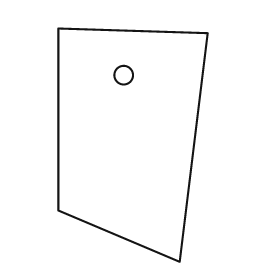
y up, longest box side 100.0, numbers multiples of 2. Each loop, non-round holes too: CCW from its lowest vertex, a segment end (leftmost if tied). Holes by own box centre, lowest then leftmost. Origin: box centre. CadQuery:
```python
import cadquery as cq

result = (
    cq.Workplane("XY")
    .moveTo(20.0, -50.0)
    .lineTo(32.0, 48.0)
    .lineTo(-32.0, 50.0)
    .lineTo(-32.0, -28.0)
    .close()
    .moveTo(-4.0, 30.0)
    .circle(4.0)
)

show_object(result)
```